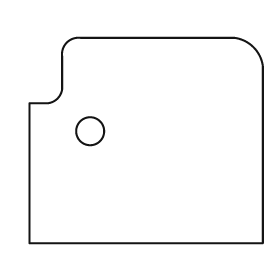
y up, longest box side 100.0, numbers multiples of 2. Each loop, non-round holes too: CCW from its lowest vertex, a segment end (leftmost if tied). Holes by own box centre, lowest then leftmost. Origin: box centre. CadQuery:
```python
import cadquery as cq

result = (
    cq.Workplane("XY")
    .moveTo(-50.0, -44.0)
    .lineTo(50.0, -44.0)
    .lineTo(50.0, 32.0)
    .threePointArc((46.0, 40.0), (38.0, 44.0))
    .lineTo(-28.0, 44.0)
    .threePointArc((-34.0, 42.0), (-36.0, 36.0))
    .lineTo(-36.0, 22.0)
    .threePointArc((-38.0, 18.0), (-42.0, 16.0))
    .lineTo(-50.0, 16.0)
    .close()
    .moveTo(-24.0, 4.0)
    .circle(6.0)
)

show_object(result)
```